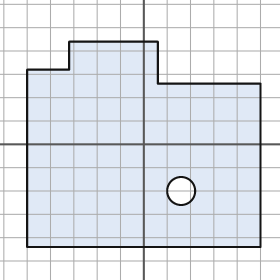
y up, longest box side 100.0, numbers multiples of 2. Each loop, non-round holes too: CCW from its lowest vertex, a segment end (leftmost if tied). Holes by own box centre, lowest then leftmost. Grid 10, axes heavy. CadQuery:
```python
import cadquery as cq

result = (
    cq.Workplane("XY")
    .moveTo(-50.0, -44.0)
    .lineTo(50.0, -44.0)
    .lineTo(50.0, 26.0)
    .lineTo(6.0, 26.0)
    .lineTo(6.0, 44.0)
    .lineTo(-32.0, 44.0)
    .lineTo(-32.0, 32.0)
    .lineTo(-50.0, 32.0)
    .close()
    .moveTo(16.0, -20.0)
    .circle(6.0)
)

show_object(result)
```